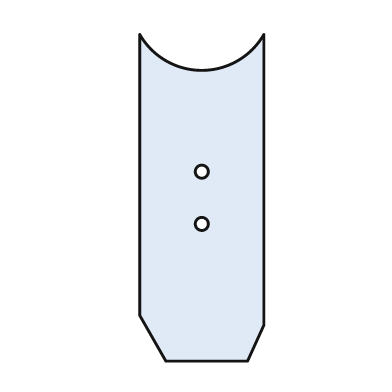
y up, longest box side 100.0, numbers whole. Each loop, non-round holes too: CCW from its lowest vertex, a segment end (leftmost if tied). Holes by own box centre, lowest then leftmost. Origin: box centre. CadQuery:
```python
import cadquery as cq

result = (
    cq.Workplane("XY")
    .moveTo(-11.0, -50.0)
    .lineTo(14.0, -50.0)
    .lineTo(19.0, -39.0)
    .lineTo(19.0, 50.0)
    .threePointArc((0.0, 39.0), (-19.0, 50.0))
    .lineTo(-19.0, -36.0)
    .close()
    .moveTo(0.0, -8.0)
    .circle(2.0)
    .moveTo(0.0, 8.0)
    .circle(2.0)
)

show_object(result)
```